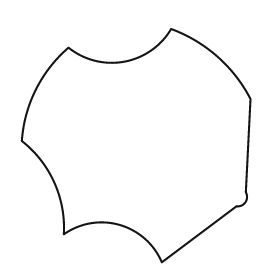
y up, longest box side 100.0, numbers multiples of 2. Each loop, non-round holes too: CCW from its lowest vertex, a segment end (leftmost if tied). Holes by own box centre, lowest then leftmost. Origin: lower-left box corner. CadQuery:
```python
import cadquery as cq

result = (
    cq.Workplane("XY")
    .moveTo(60.0, 0.0)
    .lineTo(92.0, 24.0)
    .threePointArc((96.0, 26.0), (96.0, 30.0))
    .lineTo(98.0, 70.0)
    .threePointArc((84.0, 88.0), (64.0, 100.0))
    .threePointArc((44.0, 86.0), (20.0, 92.0))
    .threePointArc((6.0, 74.0), (0.0, 52.0))
    .threePointArc((14.0, 34.0), (18.0, 12.0))
    .threePointArc((42.0, 16.0), (60.0, 0.0))
    .close()
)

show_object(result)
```